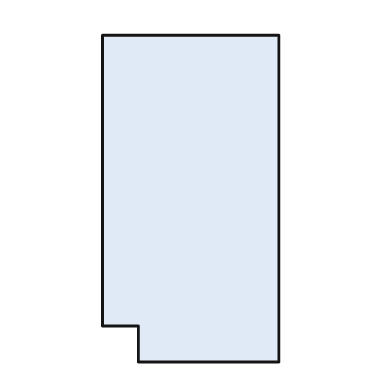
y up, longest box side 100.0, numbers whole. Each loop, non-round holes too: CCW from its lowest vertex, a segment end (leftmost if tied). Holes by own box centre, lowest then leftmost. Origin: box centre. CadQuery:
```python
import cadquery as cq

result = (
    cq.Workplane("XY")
    .moveTo(-16.0, -50.0)
    .lineTo(27.0, -50.0)
    .lineTo(27.0, 50.0)
    .lineTo(-27.0, 50.0)
    .lineTo(-27.0, -39.0)
    .lineTo(-16.0, -39.0)
    .close()
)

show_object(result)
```